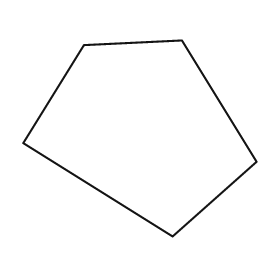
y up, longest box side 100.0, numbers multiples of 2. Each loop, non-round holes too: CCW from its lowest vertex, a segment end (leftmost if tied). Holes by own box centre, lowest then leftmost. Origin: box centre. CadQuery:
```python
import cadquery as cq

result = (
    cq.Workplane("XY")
    .moveTo(14.0, -42.0)
    .lineTo(50.0, -10.0)
    .lineTo(18.0, 42.0)
    .lineTo(-24.0, 40.0)
    .lineTo(-50.0, -2.0)
    .close()
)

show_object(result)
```